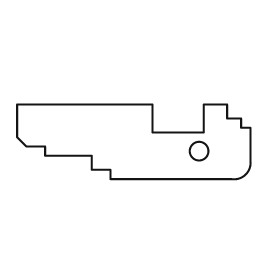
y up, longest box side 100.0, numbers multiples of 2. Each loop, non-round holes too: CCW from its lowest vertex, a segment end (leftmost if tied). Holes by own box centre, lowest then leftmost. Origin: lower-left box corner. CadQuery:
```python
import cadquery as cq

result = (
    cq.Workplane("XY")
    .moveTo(40.0, 0.0)
    .lineTo(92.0, 0.0)
    .threePointArc((98.0, 2.0), (100.0, 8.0))
    .lineTo(100.0, 22.0)
    .lineTo(96.0, 22.0)
    .lineTo(96.0, 26.0)
    .lineTo(90.0, 26.0)
    .lineTo(90.0, 32.0)
    .lineTo(80.0, 32.0)
    .lineTo(80.0, 20.0)
    .lineTo(58.0, 20.0)
    .lineTo(58.0, 32.0)
    .lineTo(0.0, 32.0)
    .lineTo(0.0, 18.0)
    .lineTo(4.0, 14.0)
    .lineTo(12.0, 14.0)
    .lineTo(12.0, 10.0)
    .lineTo(32.0, 10.0)
    .lineTo(32.0, 4.0)
    .lineTo(40.0, 4.0)
    .close()
    .moveTo(78.0, 12.0)
    .circle(4.0)
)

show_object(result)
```